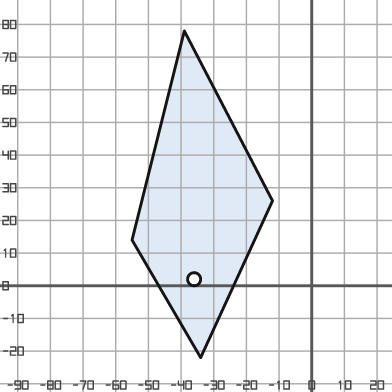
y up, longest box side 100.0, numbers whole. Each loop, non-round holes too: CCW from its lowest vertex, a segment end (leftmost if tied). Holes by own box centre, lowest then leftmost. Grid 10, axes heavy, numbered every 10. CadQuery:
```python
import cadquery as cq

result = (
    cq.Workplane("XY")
    .moveTo(-34.0, -22.0)
    .lineTo(-12.0, 26.0)
    .lineTo(-39.0, 78.0)
    .lineTo(-55.0, 14.0)
    .close()
    .moveTo(-36.0, 2.0)
    .circle(2.0)
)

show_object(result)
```